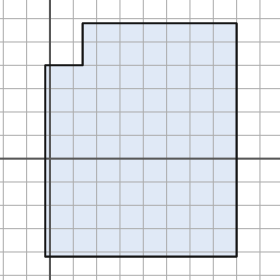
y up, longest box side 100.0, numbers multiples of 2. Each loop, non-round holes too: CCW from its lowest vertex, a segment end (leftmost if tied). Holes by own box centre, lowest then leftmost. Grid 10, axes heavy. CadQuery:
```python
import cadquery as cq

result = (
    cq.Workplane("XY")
    .moveTo(-2.0, -42.0)
    .lineTo(80.0, -42.0)
    .lineTo(80.0, 58.0)
    .lineTo(14.0, 58.0)
    .lineTo(14.0, 40.0)
    .lineTo(-2.0, 40.0)
    .close()
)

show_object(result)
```